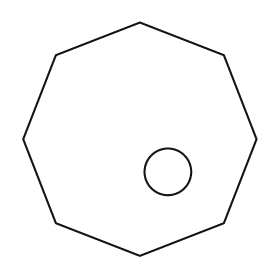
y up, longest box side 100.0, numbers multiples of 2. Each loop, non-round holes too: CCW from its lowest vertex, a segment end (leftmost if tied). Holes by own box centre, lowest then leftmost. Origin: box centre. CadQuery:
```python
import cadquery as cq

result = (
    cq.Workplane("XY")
    .moveTo(0.0, -50.0)
    .lineTo(36.0, -36.0)
    .lineTo(50.0, 0.0)
    .lineTo(36.0, 36.0)
    .lineTo(0.0, 50.0)
    .lineTo(-36.0, 36.0)
    .lineTo(-50.0, 0.0)
    .lineTo(-36.0, -36.0)
    .close()
    .moveTo(12.0, -14.0)
    .circle(10.0)
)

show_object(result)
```